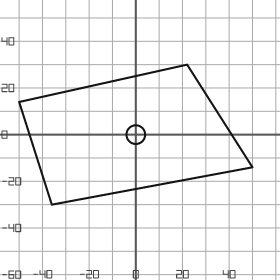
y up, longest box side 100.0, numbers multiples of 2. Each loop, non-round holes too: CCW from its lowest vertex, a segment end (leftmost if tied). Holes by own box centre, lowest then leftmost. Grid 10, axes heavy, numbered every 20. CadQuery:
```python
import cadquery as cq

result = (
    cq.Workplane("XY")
    .moveTo(-36.0, -30.0)
    .lineTo(50.0, -14.0)
    .lineTo(22.0, 30.0)
    .lineTo(-50.0, 14.0)
    .close()
    .moveTo(0.0, 0.0)
    .circle(4.0)
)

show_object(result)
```